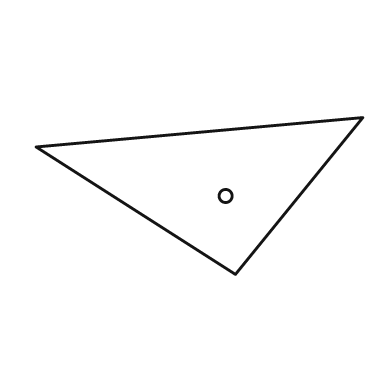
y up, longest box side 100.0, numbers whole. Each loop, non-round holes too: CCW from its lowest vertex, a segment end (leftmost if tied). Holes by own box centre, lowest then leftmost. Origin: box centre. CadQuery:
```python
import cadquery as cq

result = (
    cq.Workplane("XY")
    .moveTo(11.0, -24.0)
    .lineTo(50.0, 24.0)
    .lineTo(-50.0, 15.0)
    .close()
    .moveTo(8.0, 0.0)
    .circle(2.0)
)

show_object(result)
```